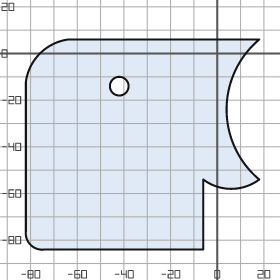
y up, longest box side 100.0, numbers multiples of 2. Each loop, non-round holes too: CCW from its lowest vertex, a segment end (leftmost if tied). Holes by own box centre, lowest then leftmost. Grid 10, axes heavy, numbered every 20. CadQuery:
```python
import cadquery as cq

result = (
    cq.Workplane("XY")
    .moveTo(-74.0, -84.0)
    .lineTo(-6.0, -84.0)
    .lineTo(-6.0, -54.0)
    .threePointArc((6.0, -58.0), (18.0, -54.0))
    .threePointArc((4.0, -24.0), (18.0, 6.0))
    .lineTo(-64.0, 6.0)
    .threePointArc((-76.0, 0.0), (-82.0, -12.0))
    .lineTo(-82.0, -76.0)
    .threePointArc((-80.0, -82.0), (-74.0, -84.0))
    .close()
    .moveTo(-42.0, -14.0)
    .circle(4.0)
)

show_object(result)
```